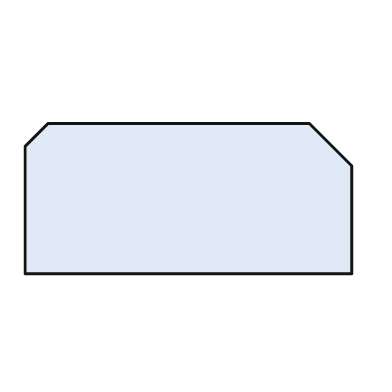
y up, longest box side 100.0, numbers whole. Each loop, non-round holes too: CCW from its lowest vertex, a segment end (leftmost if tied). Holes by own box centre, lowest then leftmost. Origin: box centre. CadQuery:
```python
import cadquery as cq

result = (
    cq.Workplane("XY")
    .moveTo(-50.0, -23.0)
    .lineTo(50.0, -23.0)
    .lineTo(50.0, 10.0)
    .lineTo(37.0, 23.0)
    .lineTo(-43.0, 23.0)
    .lineTo(-50.0, 16.0)
    .close()
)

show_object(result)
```